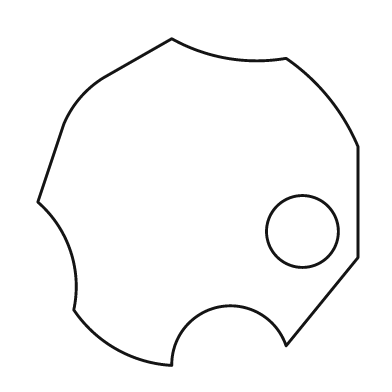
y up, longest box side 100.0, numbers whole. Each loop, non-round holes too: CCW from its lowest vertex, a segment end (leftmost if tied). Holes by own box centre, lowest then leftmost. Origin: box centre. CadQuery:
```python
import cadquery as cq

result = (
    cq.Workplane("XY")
    .moveTo(-8.0, -50.0)
    .threePointArc((7.0, -32.0), (27.0, -44.0))
    .lineTo(49.0, -17.0)
    .lineTo(49.0, 17.0)
    .threePointArc((40.0, 32.0), (27.0, 44.0))
    .threePointArc((9.0, 44.0), (-8.0, 50.0))
    .lineTo(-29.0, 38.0)
    .threePointArc((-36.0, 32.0), (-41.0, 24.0))
    .lineTo(-49.0, 0.0)
    .threePointArc((-39.0, -15.0), (-38.0, -33.0))
    .threePointArc((-25.0, -45.0), (-8.0, -50.0))
    .close()
    .moveTo(32.0, -9.0)
    .circle(11.0)
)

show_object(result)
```